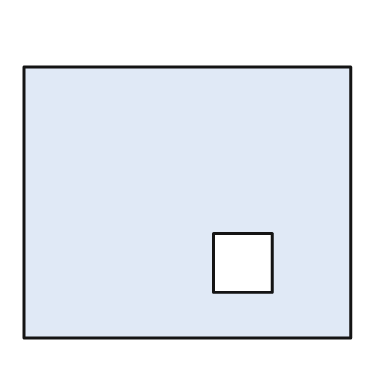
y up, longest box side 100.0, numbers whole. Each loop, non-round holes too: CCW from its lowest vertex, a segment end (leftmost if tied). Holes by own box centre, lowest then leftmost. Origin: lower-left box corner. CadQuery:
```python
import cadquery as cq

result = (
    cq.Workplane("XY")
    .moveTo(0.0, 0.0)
    .lineTo(100.0, 0.0)
    .lineTo(100.0, 83.0)
    .lineTo(0.0, 83.0)
    .close()
    .moveTo(58.0, 14.0)
    .lineTo(76.0, 14.0)
    .lineTo(76.0, 32.0)
    .lineTo(58.0, 32.0)
    .close()
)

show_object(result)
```